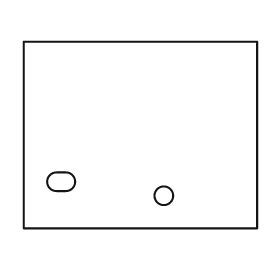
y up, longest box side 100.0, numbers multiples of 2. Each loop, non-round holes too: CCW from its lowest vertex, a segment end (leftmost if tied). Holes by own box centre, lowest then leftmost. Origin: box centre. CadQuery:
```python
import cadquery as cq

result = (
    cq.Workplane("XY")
    .moveTo(-50.0, -40.0)
    .lineTo(50.0, -40.0)
    .lineTo(50.0, 40.0)
    .lineTo(-50.0, 40.0)
    .close()
    .moveTo(10.0, -26.0)
    .circle(4.0)
    .moveTo(-36.0, -24.0)
    .lineTo(-32.0, -24.0)
    .threePointArc((-28.0, -20.0), (-32.0, -16.0))
    .lineTo(-36.0, -16.0)
    .threePointArc((-40.0, -20.0), (-36.0, -24.0))
    .close()
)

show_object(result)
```